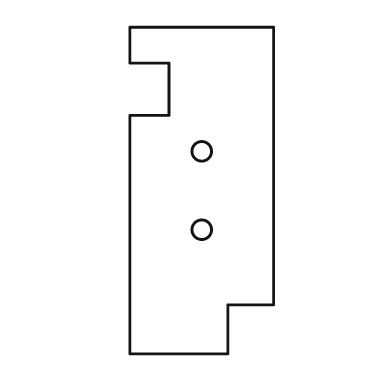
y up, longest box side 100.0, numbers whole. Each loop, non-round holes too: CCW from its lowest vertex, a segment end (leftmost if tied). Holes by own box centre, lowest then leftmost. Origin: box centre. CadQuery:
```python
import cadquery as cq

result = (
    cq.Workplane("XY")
    .moveTo(-22.0, -50.0)
    .lineTo(8.0, -50.0)
    .lineTo(8.0, -35.0)
    .lineTo(22.0, -35.0)
    .lineTo(22.0, 50.0)
    .lineTo(-22.0, 50.0)
    .lineTo(-22.0, 39.0)
    .lineTo(-10.0, 39.0)
    .lineTo(-10.0, 23.0)
    .lineTo(-22.0, 23.0)
    .close()
    .moveTo(0.0, -12.0)
    .circle(3.0)
    .moveTo(0.0, 12.0)
    .circle(3.0)
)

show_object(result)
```